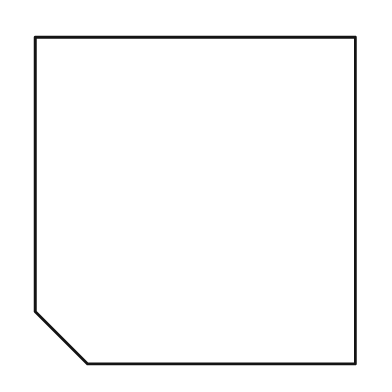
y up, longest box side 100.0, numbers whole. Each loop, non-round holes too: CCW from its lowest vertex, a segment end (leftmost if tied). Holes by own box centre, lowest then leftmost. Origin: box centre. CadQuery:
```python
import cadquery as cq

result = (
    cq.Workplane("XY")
    .moveTo(-33.0, -50.0)
    .lineTo(49.0, -50.0)
    .lineTo(49.0, 50.0)
    .lineTo(-49.0, 50.0)
    .lineTo(-49.0, -34.0)
    .close()
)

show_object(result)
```